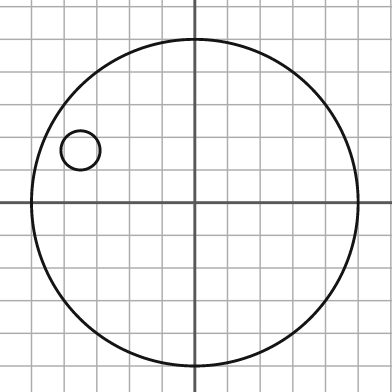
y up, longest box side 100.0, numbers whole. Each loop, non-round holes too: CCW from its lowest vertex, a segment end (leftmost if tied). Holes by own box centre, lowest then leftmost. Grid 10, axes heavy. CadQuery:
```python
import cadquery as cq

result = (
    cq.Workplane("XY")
    .moveTo(0.0, 0.0)
    .circle(50.0)
    .moveTo(-35.0, 16.0)
    .circle(6.0)
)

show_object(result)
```